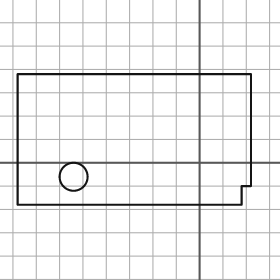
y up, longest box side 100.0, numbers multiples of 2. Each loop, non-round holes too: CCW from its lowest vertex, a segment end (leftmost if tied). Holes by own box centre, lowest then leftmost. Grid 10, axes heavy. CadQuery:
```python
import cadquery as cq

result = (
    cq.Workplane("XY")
    .moveTo(-78.0, -18.0)
    .lineTo(18.0, -18.0)
    .lineTo(18.0, -10.0)
    .lineTo(22.0, -10.0)
    .lineTo(22.0, 38.0)
    .lineTo(-78.0, 38.0)
    .close()
    .moveTo(-54.0, -6.0)
    .circle(6.0)
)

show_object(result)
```